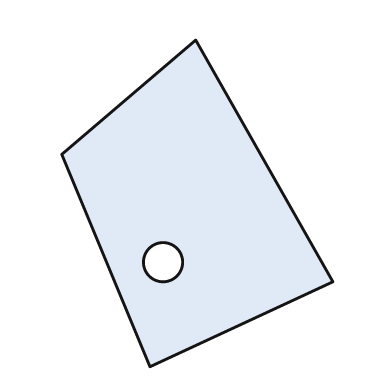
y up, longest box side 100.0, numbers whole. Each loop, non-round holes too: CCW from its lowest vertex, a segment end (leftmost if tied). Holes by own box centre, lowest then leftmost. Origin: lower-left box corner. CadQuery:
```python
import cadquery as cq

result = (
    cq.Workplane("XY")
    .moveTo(27.0, 0.0)
    .lineTo(83.0, 26.0)
    .lineTo(41.0, 100.0)
    .lineTo(0.0, 65.0)
    .close()
    .moveTo(31.0, 32.0)
    .circle(6.0)
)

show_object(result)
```